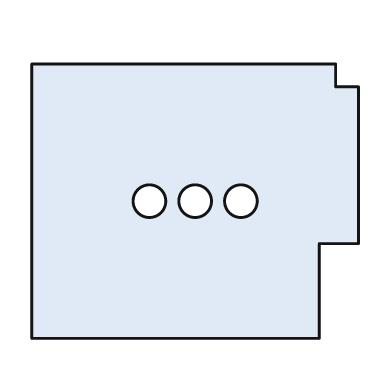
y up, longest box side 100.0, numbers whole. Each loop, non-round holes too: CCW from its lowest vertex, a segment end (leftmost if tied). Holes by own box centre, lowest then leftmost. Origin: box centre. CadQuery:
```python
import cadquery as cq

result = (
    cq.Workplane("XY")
    .moveTo(-50.0, -42.0)
    .lineTo(38.0, -42.0)
    .lineTo(38.0, -13.0)
    .lineTo(50.0, -13.0)
    .lineTo(50.0, 35.0)
    .lineTo(43.0, 35.0)
    .lineTo(43.0, 42.0)
    .lineTo(-50.0, 42.0)
    .close()
    .moveTo(-14.0, 0.0)
    .circle(5.0)
    .moveTo(0.0, 0.0)
    .circle(5.0)
    .moveTo(14.0, 0.0)
    .circle(5.0)
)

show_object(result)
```